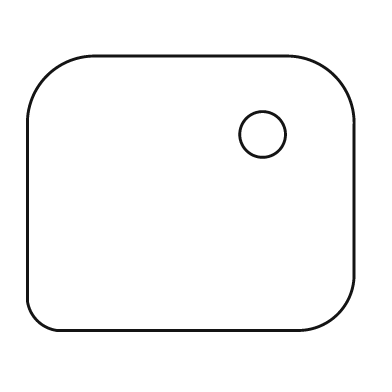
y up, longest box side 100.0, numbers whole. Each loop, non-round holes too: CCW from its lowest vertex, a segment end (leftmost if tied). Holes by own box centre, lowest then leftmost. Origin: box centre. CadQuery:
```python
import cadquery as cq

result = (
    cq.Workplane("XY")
    .moveTo(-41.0, -42.0)
    .lineTo(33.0, -42.0)
    .threePointArc((45.0, -37.0), (50.0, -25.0))
    .lineTo(50.0, 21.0)
    .threePointArc((44.0, 36.0), (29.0, 42.0))
    .lineTo(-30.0, 42.0)
    .threePointArc((-44.0, 36.0), (-50.0, 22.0))
    .lineTo(-50.0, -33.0)
    .threePointArc((-47.0, -39.0), (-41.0, -42.0))
    .close()
    .moveTo(22.0, 18.0)
    .circle(7.0)
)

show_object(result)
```